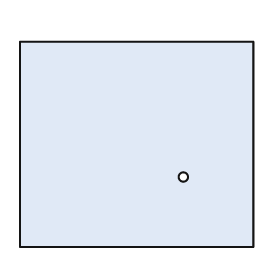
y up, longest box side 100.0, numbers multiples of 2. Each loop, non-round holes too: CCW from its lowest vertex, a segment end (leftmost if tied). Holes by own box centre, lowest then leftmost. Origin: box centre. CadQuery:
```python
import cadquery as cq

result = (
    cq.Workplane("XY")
    .moveTo(-50.0, -44.0)
    .lineTo(50.0, -44.0)
    .lineTo(50.0, 44.0)
    .lineTo(-50.0, 44.0)
    .close()
    .moveTo(20.0, -14.0)
    .circle(2.0)
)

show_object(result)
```